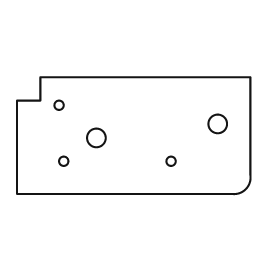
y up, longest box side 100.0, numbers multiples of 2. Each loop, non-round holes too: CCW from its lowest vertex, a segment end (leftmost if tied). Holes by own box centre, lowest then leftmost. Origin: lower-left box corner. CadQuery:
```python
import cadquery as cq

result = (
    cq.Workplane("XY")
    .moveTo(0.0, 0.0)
    .lineTo(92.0, 0.0)
    .threePointArc((98.0, 2.0), (100.0, 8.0))
    .lineTo(100.0, 50.0)
    .lineTo(10.0, 50.0)
    .lineTo(10.0, 40.0)
    .lineTo(0.0, 40.0)
    .close()
    .moveTo(20.0, 14.0)
    .circle(2.0)
    .moveTo(66.0, 14.0)
    .circle(2.0)
    .moveTo(34.0, 24.0)
    .circle(4.0)
    .moveTo(86.0, 30.0)
    .circle(4.0)
    .moveTo(18.0, 38.0)
    .circle(2.0)
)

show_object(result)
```